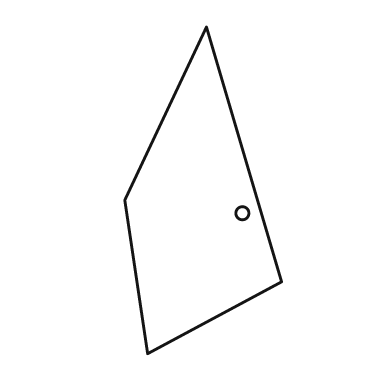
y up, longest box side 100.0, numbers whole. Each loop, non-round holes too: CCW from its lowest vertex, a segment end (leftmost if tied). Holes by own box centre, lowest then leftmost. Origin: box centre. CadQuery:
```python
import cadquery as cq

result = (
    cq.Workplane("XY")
    .moveTo(-17.0, -50.0)
    .lineTo(24.0, -28.0)
    .lineTo(1.0, 50.0)
    .lineTo(-24.0, -3.0)
    .close()
    .moveTo(12.0, -7.0)
    .circle(2.0)
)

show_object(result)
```